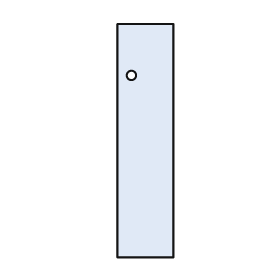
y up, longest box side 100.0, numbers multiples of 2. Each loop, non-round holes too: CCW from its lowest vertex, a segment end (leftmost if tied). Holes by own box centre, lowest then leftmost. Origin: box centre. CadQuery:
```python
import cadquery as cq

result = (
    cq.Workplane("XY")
    .moveTo(-12.0, -50.0)
    .lineTo(12.0, -50.0)
    .lineTo(12.0, 50.0)
    .lineTo(-12.0, 50.0)
    .close()
    .moveTo(-6.0, 28.0)
    .circle(2.0)
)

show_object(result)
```